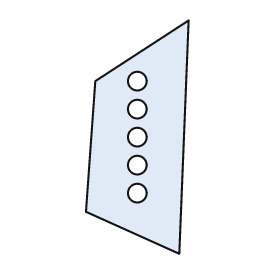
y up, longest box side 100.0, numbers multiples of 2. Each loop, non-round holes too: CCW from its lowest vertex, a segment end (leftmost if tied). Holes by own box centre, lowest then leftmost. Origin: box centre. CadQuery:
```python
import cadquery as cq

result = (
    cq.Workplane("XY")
    .moveTo(18.0, -50.0)
    .lineTo(22.0, 50.0)
    .lineTo(-18.0, 24.0)
    .lineTo(-22.0, -32.0)
    .close()
    .moveTo(0.0, -24.0)
    .circle(4.0)
    .moveTo(0.0, -12.0)
    .circle(4.0)
    .moveTo(0.0, 0.0)
    .circle(4.0)
    .moveTo(0.0, 12.0)
    .circle(4.0)
    .moveTo(0.0, 24.0)
    .circle(4.0)
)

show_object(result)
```